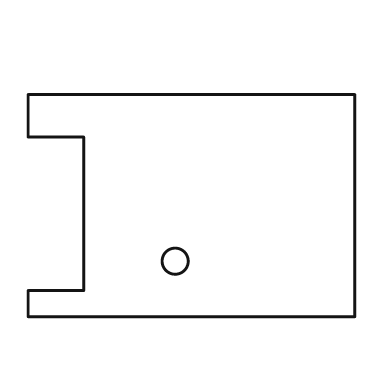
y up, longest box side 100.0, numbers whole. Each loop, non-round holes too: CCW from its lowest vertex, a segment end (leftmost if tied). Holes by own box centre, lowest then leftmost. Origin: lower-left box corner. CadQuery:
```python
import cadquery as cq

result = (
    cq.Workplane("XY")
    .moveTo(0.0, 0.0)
    .lineTo(100.0, 0.0)
    .lineTo(100.0, 68.0)
    .lineTo(0.0, 68.0)
    .lineTo(0.0, 55.0)
    .lineTo(17.0, 55.0)
    .lineTo(17.0, 8.0)
    .lineTo(0.0, 8.0)
    .close()
    .moveTo(45.0, 17.0)
    .circle(4.0)
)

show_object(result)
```